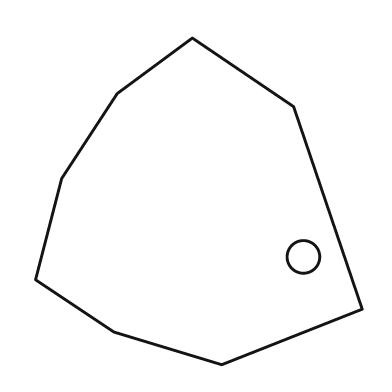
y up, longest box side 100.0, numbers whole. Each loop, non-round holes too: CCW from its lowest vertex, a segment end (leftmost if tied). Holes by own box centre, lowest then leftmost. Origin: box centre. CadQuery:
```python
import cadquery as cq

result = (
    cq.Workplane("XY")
    .moveTo(7.0, -50.0)
    .lineTo(50.0, -33.0)
    .lineTo(29.0, 29.0)
    .lineTo(-2.0, 50.0)
    .lineTo(-25.0, 33.0)
    .lineTo(-42.0, 7.0)
    .lineTo(-50.0, -24.0)
    .lineTo(-26.0, -40.0)
    .close()
    .moveTo(32.0, -17.0)
    .circle(5.0)
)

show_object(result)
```